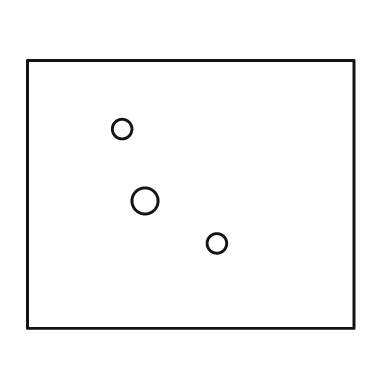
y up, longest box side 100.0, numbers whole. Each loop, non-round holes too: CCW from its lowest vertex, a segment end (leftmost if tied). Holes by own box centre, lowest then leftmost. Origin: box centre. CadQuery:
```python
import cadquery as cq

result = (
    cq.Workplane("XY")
    .moveTo(-50.0, -41.0)
    .lineTo(50.0, -41.0)
    .lineTo(50.0, 41.0)
    .lineTo(-50.0, 41.0)
    .close()
    .moveTo(8.0, -15.0)
    .circle(3.0)
    .moveTo(-14.0, -2.0)
    .circle(4.0)
    .moveTo(-21.0, 20.0)
    .circle(3.0)
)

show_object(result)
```